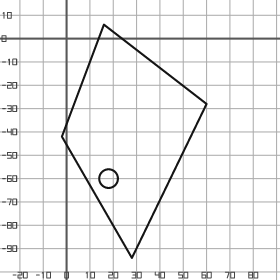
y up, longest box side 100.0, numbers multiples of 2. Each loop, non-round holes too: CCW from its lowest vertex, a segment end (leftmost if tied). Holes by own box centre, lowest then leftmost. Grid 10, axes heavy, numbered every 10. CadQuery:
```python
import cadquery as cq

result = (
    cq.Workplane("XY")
    .moveTo(28.0, -94.0)
    .lineTo(60.0, -28.0)
    .lineTo(16.0, 6.0)
    .lineTo(-2.0, -42.0)
    .close()
    .moveTo(18.0, -60.0)
    .circle(4.0)
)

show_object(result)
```